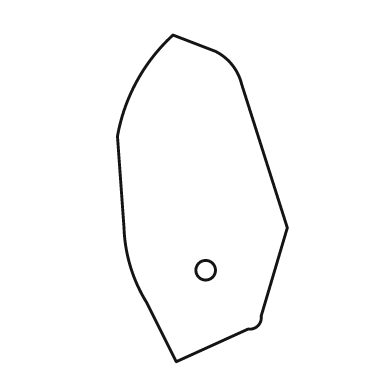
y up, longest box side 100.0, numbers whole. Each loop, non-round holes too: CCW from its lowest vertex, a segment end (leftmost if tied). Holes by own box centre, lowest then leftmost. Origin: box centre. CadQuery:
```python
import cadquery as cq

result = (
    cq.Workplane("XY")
    .moveTo(-8.0, -50.0)
    .lineTo(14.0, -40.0)
    .threePointArc((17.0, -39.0), (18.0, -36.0))
    .lineTo(26.0, -9.0)
    .lineTo(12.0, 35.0)
    .threePointArc((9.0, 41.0), (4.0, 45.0))
    .lineTo(-9.0, 50.0)
    .threePointArc((-20.0, 36.0), (-26.0, 19.0))
    .lineTo(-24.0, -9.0)
    .threePointArc((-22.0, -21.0), (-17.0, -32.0))
    .close()
    .moveTo(1.0, -22.0)
    .circle(3.0)
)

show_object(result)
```